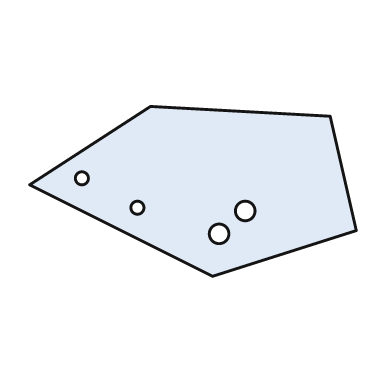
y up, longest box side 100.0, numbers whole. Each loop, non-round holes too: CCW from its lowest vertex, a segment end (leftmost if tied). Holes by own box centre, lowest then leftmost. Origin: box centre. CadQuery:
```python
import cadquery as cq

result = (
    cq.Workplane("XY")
    .moveTo(6.0, -26.0)
    .lineTo(50.0, -12.0)
    .lineTo(42.0, 23.0)
    .lineTo(-13.0, 26.0)
    .lineTo(-50.0, 2.0)
    .close()
    .moveTo(8.0, -13.0)
    .circle(3.0)
    .moveTo(16.0, -6.0)
    .circle(3.0)
    .moveTo(-17.0, -5.0)
    .circle(2.0)
    .moveTo(-34.0, 4.0)
    .circle(2.0)
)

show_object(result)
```